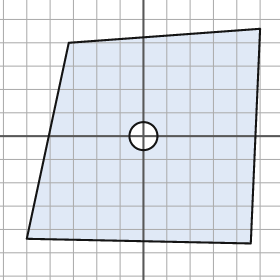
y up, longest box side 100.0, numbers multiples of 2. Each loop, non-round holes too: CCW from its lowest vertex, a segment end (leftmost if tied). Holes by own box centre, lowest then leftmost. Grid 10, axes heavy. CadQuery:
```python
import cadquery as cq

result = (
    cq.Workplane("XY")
    .moveTo(46.0, -46.0)
    .lineTo(50.0, 46.0)
    .lineTo(-32.0, 40.0)
    .lineTo(-50.0, -44.0)
    .close()
    .moveTo(0.0, 0.0)
    .circle(6.0)
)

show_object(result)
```